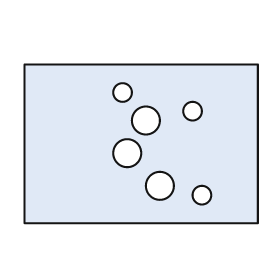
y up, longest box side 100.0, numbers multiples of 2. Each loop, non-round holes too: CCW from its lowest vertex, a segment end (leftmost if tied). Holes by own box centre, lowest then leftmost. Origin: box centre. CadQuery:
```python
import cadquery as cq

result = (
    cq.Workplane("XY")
    .moveTo(-50.0, -34.0)
    .lineTo(50.0, -34.0)
    .lineTo(50.0, 34.0)
    .lineTo(-50.0, 34.0)
    .close()
    .moveTo(26.0, -22.0)
    .circle(4.0)
    .moveTo(8.0, -18.0)
    .circle(6.0)
    .moveTo(-6.0, -4.0)
    .circle(6.0)
    .moveTo(2.0, 10.0)
    .circle(6.0)
    .moveTo(22.0, 14.0)
    .circle(4.0)
    .moveTo(-8.0, 22.0)
    .circle(4.0)
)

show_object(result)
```